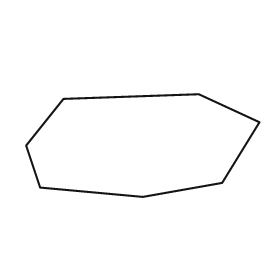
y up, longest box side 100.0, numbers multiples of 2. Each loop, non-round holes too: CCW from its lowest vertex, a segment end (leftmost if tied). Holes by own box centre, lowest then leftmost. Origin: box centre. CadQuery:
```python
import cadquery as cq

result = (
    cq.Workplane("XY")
    .moveTo(0.0, -22.0)
    .lineTo(34.0, -16.0)
    .lineTo(50.0, 10.0)
    .lineTo(24.0, 22.0)
    .lineTo(-34.0, 20.0)
    .lineTo(-50.0, 0.0)
    .lineTo(-44.0, -18.0)
    .close()
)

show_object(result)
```